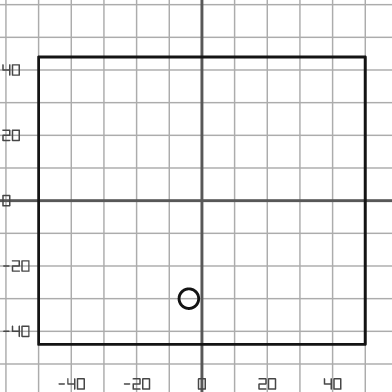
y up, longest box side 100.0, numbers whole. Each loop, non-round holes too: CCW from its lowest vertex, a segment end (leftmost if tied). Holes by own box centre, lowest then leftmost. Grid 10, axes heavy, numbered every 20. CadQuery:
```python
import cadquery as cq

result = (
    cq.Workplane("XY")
    .moveTo(-50.0, -44.0)
    .lineTo(50.0, -44.0)
    .lineTo(50.0, 44.0)
    .lineTo(-50.0, 44.0)
    .close()
    .moveTo(-4.0, -30.0)
    .circle(3.0)
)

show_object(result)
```